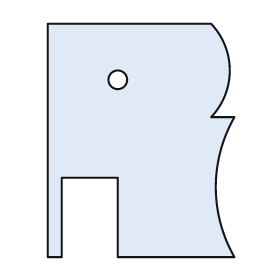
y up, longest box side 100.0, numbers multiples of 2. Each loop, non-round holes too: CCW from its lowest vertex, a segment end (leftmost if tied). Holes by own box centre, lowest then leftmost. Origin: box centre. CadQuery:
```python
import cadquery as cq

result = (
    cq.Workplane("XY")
    .moveTo(-40.0, -50.0)
    .lineTo(-34.0, -50.0)
    .lineTo(-34.0, -16.0)
    .lineTo(-10.0, -16.0)
    .lineTo(-10.0, -50.0)
    .lineTo(40.0, -50.0)
    .threePointArc((32.0, -20.0), (40.0, 10.0))
    .lineTo(30.0, 10.0)
    .threePointArc((38.0, 30.0), (30.0, 50.0))
    .lineTo(-40.0, 50.0)
    .close()
    .moveTo(-10.0, 26.0)
    .circle(4.0)
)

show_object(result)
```